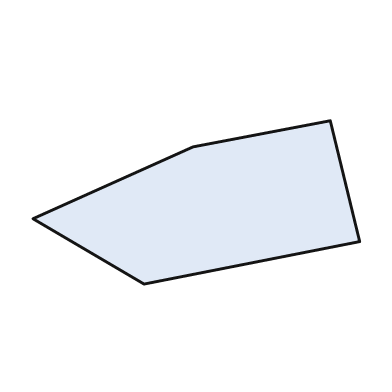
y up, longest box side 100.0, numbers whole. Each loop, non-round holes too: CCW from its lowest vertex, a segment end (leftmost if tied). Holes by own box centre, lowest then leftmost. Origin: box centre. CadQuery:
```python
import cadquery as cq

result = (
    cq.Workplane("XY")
    .moveTo(-16.0, -25.0)
    .lineTo(50.0, -12.0)
    .lineTo(41.0, 25.0)
    .lineTo(-1.0, 17.0)
    .lineTo(-50.0, -5.0)
    .close()
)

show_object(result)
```